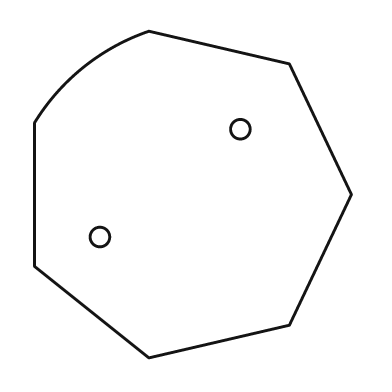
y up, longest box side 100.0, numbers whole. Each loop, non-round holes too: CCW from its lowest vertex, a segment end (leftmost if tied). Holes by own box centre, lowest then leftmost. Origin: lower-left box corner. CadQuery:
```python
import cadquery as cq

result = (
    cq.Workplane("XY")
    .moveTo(35.0, 0.0)
    .lineTo(78.0, 10.0)
    .lineTo(97.0, 50.0)
    .lineTo(78.0, 90.0)
    .lineTo(35.0, 100.0)
    .threePointArc((15.0, 89.0), (0.0, 72.0))
    .lineTo(0.0, 28.0)
    .close()
    .moveTo(20.0, 37.0)
    .circle(3.0)
    .moveTo(63.0, 70.0)
    .circle(3.0)
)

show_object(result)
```